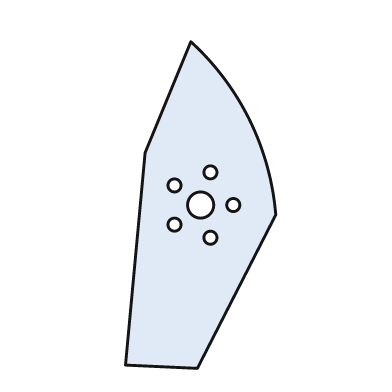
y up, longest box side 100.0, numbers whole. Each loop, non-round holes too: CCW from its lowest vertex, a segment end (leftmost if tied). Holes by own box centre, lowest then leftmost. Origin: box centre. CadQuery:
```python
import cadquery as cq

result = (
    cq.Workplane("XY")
    .moveTo(-1.0, -50.0)
    .lineTo(23.0, -3.0)
    .threePointArc((15.0, 26.0), (-3.0, 50.0))
    .lineTo(-17.0, 16.0)
    .lineTo(-23.0, -49.0)
    .close()
    .moveTo(3.0, -10.0)
    .circle(2.0)
    .moveTo(-8.0, -6.0)
    .circle(2.0)
    .moveTo(0.0, 0.0)
    .circle(4.0)
    .moveTo(10.0, 0.0)
    .circle(2.0)
    .moveTo(-8.0, 6.0)
    .circle(2.0)
    .moveTo(3.0, 10.0)
    .circle(2.0)
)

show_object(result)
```